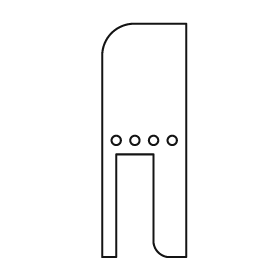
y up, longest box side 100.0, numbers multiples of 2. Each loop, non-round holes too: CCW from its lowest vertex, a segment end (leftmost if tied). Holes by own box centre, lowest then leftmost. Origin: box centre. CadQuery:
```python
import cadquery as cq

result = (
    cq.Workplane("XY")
    .moveTo(-18.0, -50.0)
    .lineTo(-12.0, -50.0)
    .lineTo(-12.0, -6.0)
    .lineTo(4.0, -6.0)
    .lineTo(4.0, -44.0)
    .threePointArc((6.0, -48.0), (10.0, -50.0))
    .lineTo(18.0, -50.0)
    .lineTo(18.0, 50.0)
    .lineTo(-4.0, 50.0)
    .threePointArc((-14.0, 46.0), (-18.0, 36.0))
    .close()
    .moveTo(-12.0, 0.0)
    .circle(2.0)
    .moveTo(-4.0, 0.0)
    .circle(2.0)
    .moveTo(4.0, 0.0)
    .circle(2.0)
    .moveTo(12.0, 0.0)
    .circle(2.0)
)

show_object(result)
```